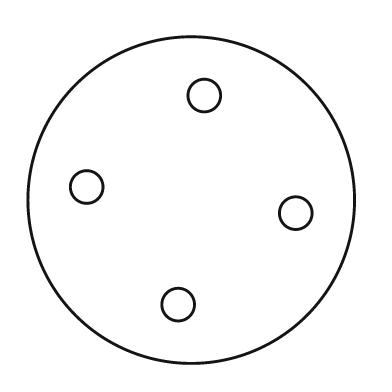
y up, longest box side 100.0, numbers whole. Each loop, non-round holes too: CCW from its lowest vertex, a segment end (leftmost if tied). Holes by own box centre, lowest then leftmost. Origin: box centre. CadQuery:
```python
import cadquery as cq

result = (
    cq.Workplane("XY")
    .moveTo(0.0, 0.0)
    .circle(50.0)
    .moveTo(-4.0, -32.0)
    .circle(5.0)
    .moveTo(32.0, -4.0)
    .circle(5.0)
    .moveTo(-32.0, 4.0)
    .circle(5.0)
    .moveTo(4.0, 32.0)
    .circle(5.0)
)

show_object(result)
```